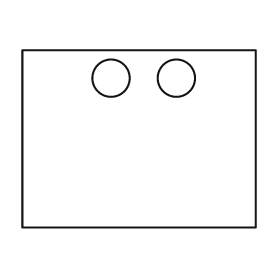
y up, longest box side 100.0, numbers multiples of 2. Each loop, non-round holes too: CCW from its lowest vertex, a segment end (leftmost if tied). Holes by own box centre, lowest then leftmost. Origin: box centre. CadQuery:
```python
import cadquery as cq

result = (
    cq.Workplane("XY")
    .moveTo(-50.0, -38.0)
    .lineTo(50.0, -38.0)
    .lineTo(50.0, 38.0)
    .lineTo(-50.0, 38.0)
    .close()
    .moveTo(-12.0, 26.0)
    .circle(8.0)
    .moveTo(16.0, 26.0)
    .circle(8.0)
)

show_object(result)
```